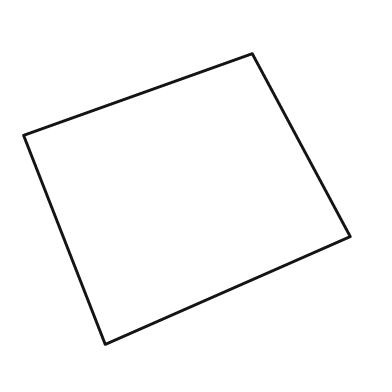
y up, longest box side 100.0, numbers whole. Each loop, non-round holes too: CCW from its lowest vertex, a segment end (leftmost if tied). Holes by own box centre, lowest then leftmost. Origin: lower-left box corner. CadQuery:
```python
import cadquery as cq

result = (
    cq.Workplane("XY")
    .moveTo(25.0, 0.0)
    .lineTo(100.0, 33.0)
    .lineTo(70.0, 89.0)
    .lineTo(0.0, 64.0)
    .close()
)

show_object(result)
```